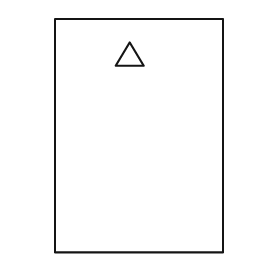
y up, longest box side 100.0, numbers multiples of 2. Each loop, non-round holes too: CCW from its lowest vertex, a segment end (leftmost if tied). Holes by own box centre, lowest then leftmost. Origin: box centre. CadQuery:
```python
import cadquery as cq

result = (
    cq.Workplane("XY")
    .moveTo(-36.0, -50.0)
    .lineTo(36.0, -50.0)
    .lineTo(36.0, 50.0)
    .lineTo(-36.0, 50.0)
    .close()
    .moveTo(-10.0, 30.0)
    .lineTo(2.0, 30.0)
    .lineTo(-4.0, 40.0)
    .close()
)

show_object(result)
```